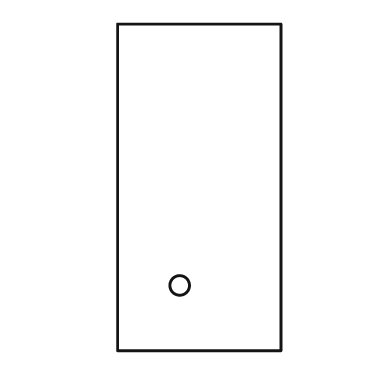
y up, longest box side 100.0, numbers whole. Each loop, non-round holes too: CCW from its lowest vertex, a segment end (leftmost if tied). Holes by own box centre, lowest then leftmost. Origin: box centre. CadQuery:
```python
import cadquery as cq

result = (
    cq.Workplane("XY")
    .moveTo(-25.0, -50.0)
    .lineTo(25.0, -50.0)
    .lineTo(25.0, 50.0)
    .lineTo(-25.0, 50.0)
    .close()
    .moveTo(-6.0, -30.0)
    .circle(3.0)
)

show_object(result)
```